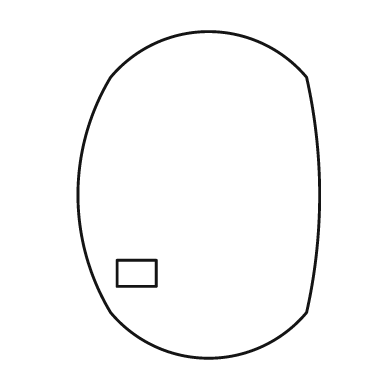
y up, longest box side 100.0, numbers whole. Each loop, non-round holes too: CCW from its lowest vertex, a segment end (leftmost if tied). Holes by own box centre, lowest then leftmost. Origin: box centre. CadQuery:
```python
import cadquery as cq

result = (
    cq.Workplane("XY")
    .moveTo(-27.0, -36.0)
    .threePointArc((3.0, -50.0), (33.0, -36.0))
    .threePointArc((37.0, 0.0), (33.0, 36.0))
    .threePointArc((3.0, 50.0), (-27.0, 36.0))
    .threePointArc((-37.0, 0.0), (-27.0, -36.0))
    .close()
    .moveTo(-25.0, -28.0)
    .lineTo(-13.0, -28.0)
    .lineTo(-13.0, -20.0)
    .lineTo(-25.0, -20.0)
    .close()
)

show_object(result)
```